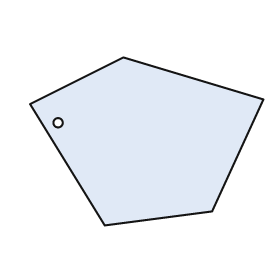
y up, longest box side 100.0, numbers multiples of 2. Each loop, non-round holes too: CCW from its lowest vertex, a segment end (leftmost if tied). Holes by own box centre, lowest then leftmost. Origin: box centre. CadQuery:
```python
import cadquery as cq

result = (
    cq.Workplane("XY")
    .moveTo(-18.0, -36.0)
    .lineTo(28.0, -30.0)
    .lineTo(50.0, 18.0)
    .lineTo(-10.0, 36.0)
    .lineTo(-50.0, 16.0)
    .close()
    .moveTo(-38.0, 8.0)
    .circle(2.0)
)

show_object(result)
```